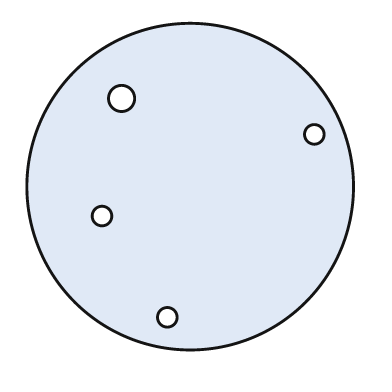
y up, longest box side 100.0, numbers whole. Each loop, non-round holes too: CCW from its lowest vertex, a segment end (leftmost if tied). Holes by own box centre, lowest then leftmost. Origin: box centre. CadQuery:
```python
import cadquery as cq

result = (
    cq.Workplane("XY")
    .moveTo(0.0, 0.0)
    .circle(50.0)
    .moveTo(-7.0, -40.0)
    .circle(3.0)
    .moveTo(-27.0, -9.0)
    .circle(3.0)
    .moveTo(38.0, 16.0)
    .circle(3.0)
    .moveTo(-21.0, 27.0)
    .circle(4.0)
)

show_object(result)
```